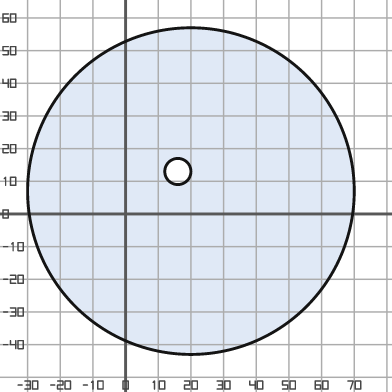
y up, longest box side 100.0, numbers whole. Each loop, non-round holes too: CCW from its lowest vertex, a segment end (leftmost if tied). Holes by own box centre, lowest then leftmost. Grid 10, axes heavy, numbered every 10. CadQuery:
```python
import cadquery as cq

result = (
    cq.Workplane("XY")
    .moveTo(20.0, 7.0)
    .circle(50.0)
    .moveTo(16.0, 13.0)
    .circle(4.0)
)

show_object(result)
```